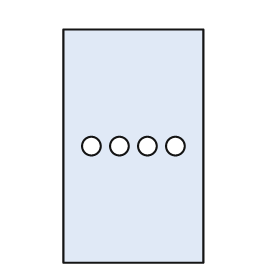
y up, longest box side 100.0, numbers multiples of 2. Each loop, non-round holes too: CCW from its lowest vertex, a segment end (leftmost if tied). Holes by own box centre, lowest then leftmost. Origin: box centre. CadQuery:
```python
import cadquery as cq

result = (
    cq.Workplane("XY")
    .moveTo(-30.0, -50.0)
    .lineTo(30.0, -50.0)
    .lineTo(30.0, 50.0)
    .lineTo(-30.0, 50.0)
    .close()
    .moveTo(-18.0, 0.0)
    .circle(4.0)
    .moveTo(-6.0, 0.0)
    .circle(4.0)
    .moveTo(6.0, 0.0)
    .circle(4.0)
    .moveTo(18.0, 0.0)
    .circle(4.0)
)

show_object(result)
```